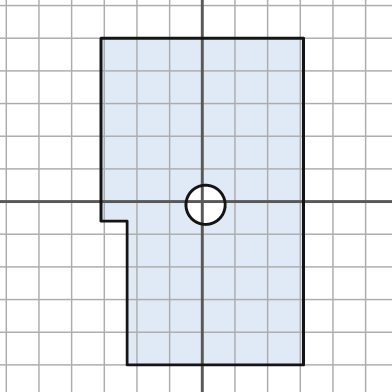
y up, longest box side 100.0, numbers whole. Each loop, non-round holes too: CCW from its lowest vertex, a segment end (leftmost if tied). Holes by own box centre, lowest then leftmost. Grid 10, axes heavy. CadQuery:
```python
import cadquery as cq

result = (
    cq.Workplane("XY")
    .moveTo(-23.0, -50.0)
    .lineTo(31.0, -50.0)
    .lineTo(31.0, 50.0)
    .lineTo(-31.0, 50.0)
    .lineTo(-31.0, -6.0)
    .lineTo(-23.0, -6.0)
    .close()
    .moveTo(1.0, -1.0)
    .circle(6.0)
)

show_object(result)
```